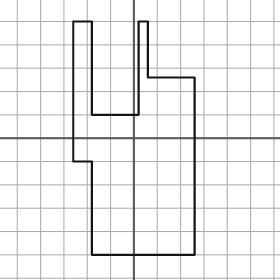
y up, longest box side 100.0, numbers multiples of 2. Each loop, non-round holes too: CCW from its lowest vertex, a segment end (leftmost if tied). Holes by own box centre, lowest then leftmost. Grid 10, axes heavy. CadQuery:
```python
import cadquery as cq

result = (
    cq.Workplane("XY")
    .moveTo(-18.0, -50.0)
    .lineTo(26.0, -50.0)
    .lineTo(26.0, 26.0)
    .lineTo(6.0, 26.0)
    .lineTo(6.0, 50.0)
    .lineTo(2.0, 50.0)
    .lineTo(2.0, 10.0)
    .lineTo(-18.0, 10.0)
    .lineTo(-18.0, 50.0)
    .lineTo(-26.0, 50.0)
    .lineTo(-26.0, -10.0)
    .lineTo(-18.0, -10.0)
    .close()
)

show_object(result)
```